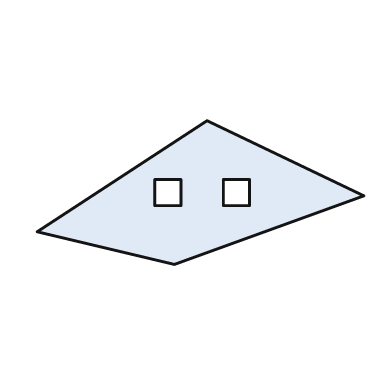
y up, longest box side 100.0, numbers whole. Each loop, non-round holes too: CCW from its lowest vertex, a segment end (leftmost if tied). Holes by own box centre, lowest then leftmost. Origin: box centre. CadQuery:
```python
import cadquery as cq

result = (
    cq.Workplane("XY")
    .moveTo(-8.0, -22.0)
    .lineTo(50.0, -1.0)
    .lineTo(2.0, 22.0)
    .lineTo(-50.0, -12.0)
    .close()
    .moveTo(-14.0, -4.0)
    .lineTo(-6.0, -4.0)
    .lineTo(-6.0, 4.0)
    .lineTo(-14.0, 4.0)
    .close()
    .moveTo(7.0, -4.0)
    .lineTo(15.0, -4.0)
    .lineTo(15.0, 4.0)
    .lineTo(7.0, 4.0)
    .close()
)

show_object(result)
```